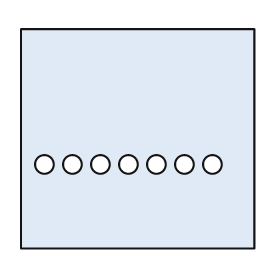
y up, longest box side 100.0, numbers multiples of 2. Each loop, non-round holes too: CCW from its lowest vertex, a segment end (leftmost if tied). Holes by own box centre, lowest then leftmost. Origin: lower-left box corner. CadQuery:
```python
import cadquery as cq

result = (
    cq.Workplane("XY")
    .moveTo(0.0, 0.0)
    .lineTo(100.0, 0.0)
    .lineTo(100.0, 94.0)
    .lineTo(0.0, 94.0)
    .close()
    .moveTo(10.0, 36.0)
    .circle(4.0)
    .moveTo(22.0, 36.0)
    .circle(4.0)
    .moveTo(34.0, 36.0)
    .circle(4.0)
    .moveTo(46.0, 36.0)
    .circle(4.0)
    .moveTo(58.0, 36.0)
    .circle(4.0)
    .moveTo(70.0, 36.0)
    .circle(4.0)
    .moveTo(82.0, 36.0)
    .circle(4.0)
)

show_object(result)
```